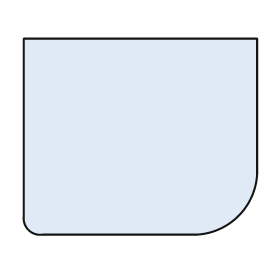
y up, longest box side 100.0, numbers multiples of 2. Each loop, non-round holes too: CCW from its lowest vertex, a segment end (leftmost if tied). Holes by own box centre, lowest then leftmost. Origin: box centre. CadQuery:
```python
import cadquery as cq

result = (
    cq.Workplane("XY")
    .moveTo(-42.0, -42.0)
    .lineTo(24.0, -42.0)
    .threePointArc((42.0, -34.0), (50.0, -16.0))
    .lineTo(50.0, 42.0)
    .lineTo(-50.0, 42.0)
    .lineTo(-50.0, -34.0)
    .threePointArc((-48.0, -40.0), (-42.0, -42.0))
    .close()
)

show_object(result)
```